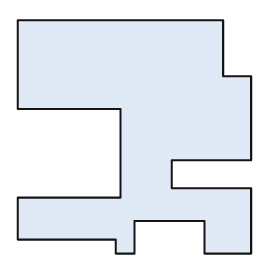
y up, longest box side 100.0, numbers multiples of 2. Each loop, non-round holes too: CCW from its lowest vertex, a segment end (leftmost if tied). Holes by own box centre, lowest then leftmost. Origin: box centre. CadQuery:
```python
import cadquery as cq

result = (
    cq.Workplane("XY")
    .moveTo(-8.0, -50.0)
    .lineTo(0.0, -50.0)
    .lineTo(0.0, -36.0)
    .lineTo(30.0, -36.0)
    .lineTo(30.0, -50.0)
    .lineTo(50.0, -50.0)
    .lineTo(50.0, -22.0)
    .lineTo(16.0, -22.0)
    .lineTo(16.0, -10.0)
    .lineTo(50.0, -10.0)
    .lineTo(50.0, 26.0)
    .lineTo(38.0, 26.0)
    .lineTo(38.0, 50.0)
    .lineTo(-50.0, 50.0)
    .lineTo(-50.0, 12.0)
    .lineTo(-6.0, 12.0)
    .lineTo(-6.0, -26.0)
    .lineTo(-50.0, -26.0)
    .lineTo(-50.0, -44.0)
    .lineTo(-8.0, -44.0)
    .close()
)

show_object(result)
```